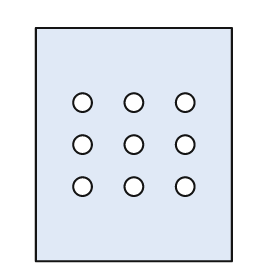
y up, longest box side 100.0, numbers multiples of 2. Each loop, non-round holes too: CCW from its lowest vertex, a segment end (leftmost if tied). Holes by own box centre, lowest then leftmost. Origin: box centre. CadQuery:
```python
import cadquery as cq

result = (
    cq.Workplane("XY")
    .moveTo(-42.0, -50.0)
    .lineTo(42.0, -50.0)
    .lineTo(42.0, 50.0)
    .lineTo(-42.0, 50.0)
    .close()
    .moveTo(-22.0, -18.0)
    .circle(4.0)
    .moveTo(0.0, -18.0)
    .circle(4.0)
    .moveTo(22.0, -18.0)
    .circle(4.0)
    .moveTo(-22.0, 0.0)
    .circle(4.0)
    .moveTo(0.0, 0.0)
    .circle(4.0)
    .moveTo(22.0, 0.0)
    .circle(4.0)
    .moveTo(-22.0, 18.0)
    .circle(4.0)
    .moveTo(0.0, 18.0)
    .circle(4.0)
    .moveTo(22.0, 18.0)
    .circle(4.0)
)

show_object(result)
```